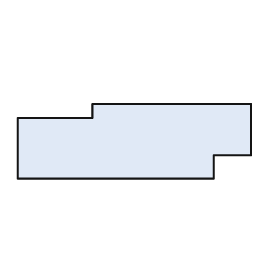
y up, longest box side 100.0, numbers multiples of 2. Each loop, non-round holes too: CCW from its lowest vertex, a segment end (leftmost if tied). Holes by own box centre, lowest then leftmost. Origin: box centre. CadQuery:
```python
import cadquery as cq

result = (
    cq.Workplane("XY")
    .moveTo(-50.0, -16.0)
    .lineTo(34.0, -16.0)
    .lineTo(34.0, -6.0)
    .lineTo(50.0, -6.0)
    .lineTo(50.0, 16.0)
    .lineTo(-18.0, 16.0)
    .lineTo(-18.0, 10.0)
    .lineTo(-50.0, 10.0)
    .close()
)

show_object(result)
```